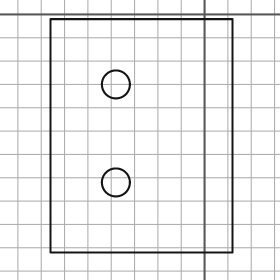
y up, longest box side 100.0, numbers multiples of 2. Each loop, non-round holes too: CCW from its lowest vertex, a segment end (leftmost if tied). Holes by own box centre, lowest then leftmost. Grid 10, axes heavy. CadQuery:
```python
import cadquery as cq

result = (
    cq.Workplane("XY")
    .moveTo(-66.0, -102.0)
    .lineTo(12.0, -102.0)
    .lineTo(12.0, -2.0)
    .lineTo(-66.0, -2.0)
    .close()
    .moveTo(-38.0, -72.0)
    .circle(6.0)
    .moveTo(-38.0, -30.0)
    .circle(6.0)
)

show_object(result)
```